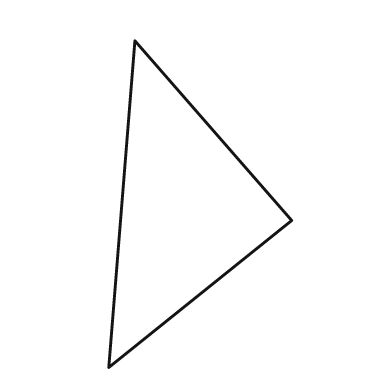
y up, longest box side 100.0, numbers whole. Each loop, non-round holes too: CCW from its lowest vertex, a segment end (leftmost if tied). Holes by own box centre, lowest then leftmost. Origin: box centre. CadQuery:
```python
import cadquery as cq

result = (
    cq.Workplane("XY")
    .moveTo(-28.0, -50.0)
    .lineTo(28.0, -5.0)
    .lineTo(-20.0, 50.0)
    .close()
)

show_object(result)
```